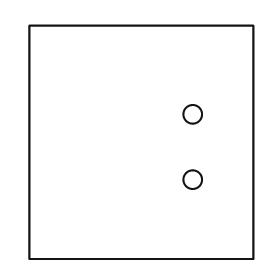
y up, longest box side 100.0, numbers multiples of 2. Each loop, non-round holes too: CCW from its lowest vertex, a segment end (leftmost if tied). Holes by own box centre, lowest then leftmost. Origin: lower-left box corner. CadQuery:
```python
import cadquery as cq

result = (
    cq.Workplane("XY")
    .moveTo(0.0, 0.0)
    .lineTo(96.0, 0.0)
    .lineTo(96.0, 100.0)
    .lineTo(0.0, 100.0)
    .close()
    .moveTo(70.0, 34.0)
    .circle(4.0)
    .moveTo(70.0, 62.0)
    .circle(4.0)
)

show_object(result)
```